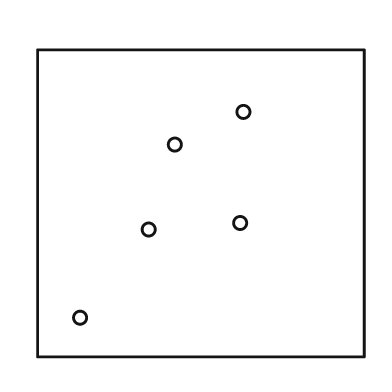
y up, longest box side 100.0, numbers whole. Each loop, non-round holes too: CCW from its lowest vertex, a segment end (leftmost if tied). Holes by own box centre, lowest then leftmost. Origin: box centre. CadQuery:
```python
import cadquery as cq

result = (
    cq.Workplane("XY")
    .moveTo(-50.0, -47.0)
    .lineTo(50.0, -47.0)
    .lineTo(50.0, 47.0)
    .lineTo(-50.0, 47.0)
    .close()
    .moveTo(-37.0, -35.0)
    .circle(2.0)
    .moveTo(-16.0, -8.0)
    .circle(2.0)
    .moveTo(12.0, -6.0)
    .circle(2.0)
    .moveTo(-8.0, 18.0)
    .circle(2.0)
    .moveTo(13.0, 28.0)
    .circle(2.0)
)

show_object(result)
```